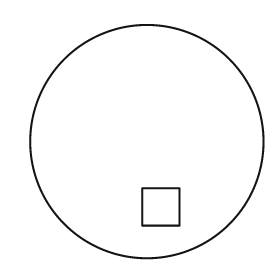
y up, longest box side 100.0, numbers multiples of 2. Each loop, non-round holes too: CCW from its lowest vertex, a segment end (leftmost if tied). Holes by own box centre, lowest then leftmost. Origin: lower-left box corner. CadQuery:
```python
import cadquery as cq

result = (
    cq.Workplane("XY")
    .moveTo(50.0, 50.0)
    .circle(50.0)
    .moveTo(48.0, 14.0)
    .lineTo(64.0, 14.0)
    .lineTo(64.0, 30.0)
    .lineTo(48.0, 30.0)
    .close()
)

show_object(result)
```